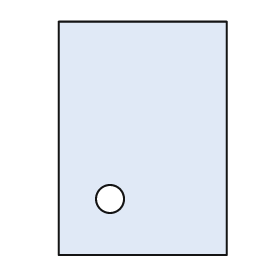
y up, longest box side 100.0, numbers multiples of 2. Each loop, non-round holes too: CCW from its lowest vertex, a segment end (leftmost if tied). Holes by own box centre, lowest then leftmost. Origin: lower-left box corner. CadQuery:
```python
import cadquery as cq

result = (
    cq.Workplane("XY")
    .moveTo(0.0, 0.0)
    .lineTo(72.0, 0.0)
    .lineTo(72.0, 100.0)
    .lineTo(0.0, 100.0)
    .close()
    .moveTo(22.0, 24.0)
    .circle(6.0)
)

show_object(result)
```